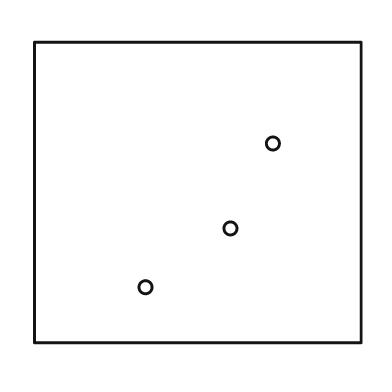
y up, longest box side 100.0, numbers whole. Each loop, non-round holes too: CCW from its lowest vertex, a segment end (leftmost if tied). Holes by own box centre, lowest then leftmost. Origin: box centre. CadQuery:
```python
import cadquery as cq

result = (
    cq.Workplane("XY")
    .moveTo(-50.0, -46.0)
    .lineTo(50.0, -46.0)
    .lineTo(50.0, 46.0)
    .lineTo(-50.0, 46.0)
    .close()
    .moveTo(-16.0, -29.0)
    .circle(2.0)
    .moveTo(10.0, -11.0)
    .circle(2.0)
    .moveTo(23.0, 15.0)
    .circle(2.0)
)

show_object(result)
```